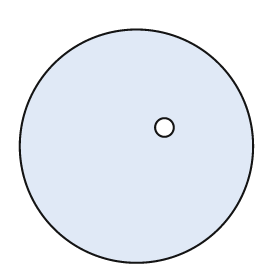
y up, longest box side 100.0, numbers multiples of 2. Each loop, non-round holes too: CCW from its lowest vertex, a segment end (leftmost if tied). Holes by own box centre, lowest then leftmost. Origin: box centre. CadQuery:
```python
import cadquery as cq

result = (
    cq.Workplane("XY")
    .moveTo(0.0, 0.0)
    .circle(50.0)
    .moveTo(12.0, 8.0)
    .circle(4.0)
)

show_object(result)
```